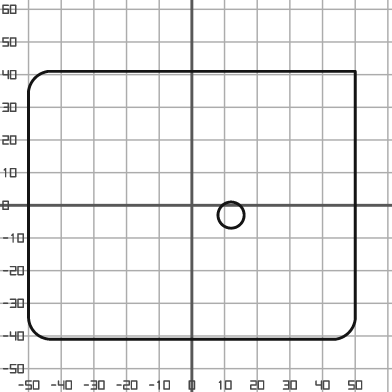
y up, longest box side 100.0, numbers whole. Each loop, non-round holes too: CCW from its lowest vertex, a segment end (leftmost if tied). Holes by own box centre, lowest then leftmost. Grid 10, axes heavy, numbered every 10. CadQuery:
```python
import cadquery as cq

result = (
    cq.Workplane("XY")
    .moveTo(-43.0, -41.0)
    .lineTo(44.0, -41.0)
    .threePointArc((48.0, -39.0), (50.0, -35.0))
    .lineTo(50.0, 41.0)
    .lineTo(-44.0, 41.0)
    .threePointArc((-48.0, 39.0), (-50.0, 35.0))
    .lineTo(-50.0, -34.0)
    .threePointArc((-48.0, -39.0), (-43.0, -41.0))
    .close()
    .moveTo(12.0, -3.0)
    .circle(4.0)
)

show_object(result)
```